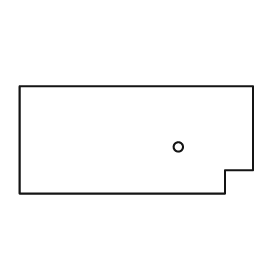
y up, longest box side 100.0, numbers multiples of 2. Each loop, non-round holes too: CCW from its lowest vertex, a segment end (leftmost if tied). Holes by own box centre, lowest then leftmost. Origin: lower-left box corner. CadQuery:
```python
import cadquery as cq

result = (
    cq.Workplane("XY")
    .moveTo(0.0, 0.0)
    .lineTo(88.0, 0.0)
    .lineTo(88.0, 10.0)
    .lineTo(100.0, 10.0)
    .lineTo(100.0, 46.0)
    .lineTo(0.0, 46.0)
    .close()
    .moveTo(68.0, 20.0)
    .circle(2.0)
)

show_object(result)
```